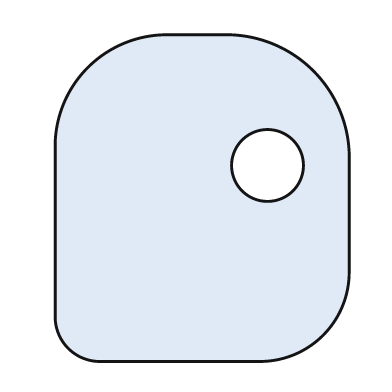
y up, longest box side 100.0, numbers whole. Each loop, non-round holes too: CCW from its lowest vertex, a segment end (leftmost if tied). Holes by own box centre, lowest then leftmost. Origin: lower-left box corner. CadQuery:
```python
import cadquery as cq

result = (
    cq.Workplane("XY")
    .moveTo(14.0, 0.0)
    .lineTo(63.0, 0.0)
    .threePointArc((82.0, 8.0), (90.0, 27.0))
    .lineTo(90.0, 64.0)
    .threePointArc((79.0, 89.0), (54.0, 100.0))
    .lineTo(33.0, 100.0)
    .threePointArc((10.0, 90.0), (0.0, 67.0))
    .lineTo(0.0, 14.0)
    .threePointArc((4.0, 4.0), (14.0, 0.0))
    .close()
    .moveTo(65.0, 60.0)
    .circle(11.0)
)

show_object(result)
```